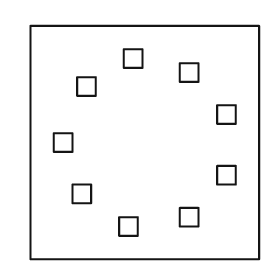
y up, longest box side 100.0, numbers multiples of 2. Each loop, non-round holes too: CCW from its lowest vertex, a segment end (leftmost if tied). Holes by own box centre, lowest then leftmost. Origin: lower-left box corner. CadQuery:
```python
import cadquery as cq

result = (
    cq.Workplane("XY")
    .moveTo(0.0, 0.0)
    .lineTo(98.0, 0.0)
    .lineTo(98.0, 100.0)
    .lineTo(0.0, 100.0)
    .close()
    .moveTo(38.0, 10.0)
    .lineTo(46.0, 10.0)
    .lineTo(46.0, 18.0)
    .lineTo(38.0, 18.0)
    .close()
    .moveTo(64.0, 14.0)
    .lineTo(72.0, 14.0)
    .lineTo(72.0, 22.0)
    .lineTo(64.0, 22.0)
    .close()
    .moveTo(18.0, 24.0)
    .lineTo(26.0, 24.0)
    .lineTo(26.0, 32.0)
    .lineTo(18.0, 32.0)
    .close()
    .moveTo(80.0, 32.0)
    .lineTo(88.0, 32.0)
    .lineTo(88.0, 40.0)
    .lineTo(80.0, 40.0)
    .close()
    .moveTo(10.0, 46.0)
    .lineTo(18.0, 46.0)
    .lineTo(18.0, 54.0)
    .lineTo(10.0, 54.0)
    .close()
    .moveTo(80.0, 58.0)
    .lineTo(88.0, 58.0)
    .lineTo(88.0, 66.0)
    .lineTo(80.0, 66.0)
    .close()
    .moveTo(20.0, 70.0)
    .lineTo(28.0, 70.0)
    .lineTo(28.0, 78.0)
    .lineTo(20.0, 78.0)
    .close()
    .moveTo(64.0, 76.0)
    .lineTo(72.0, 76.0)
    .lineTo(72.0, 84.0)
    .lineTo(64.0, 84.0)
    .close()
    .moveTo(40.0, 82.0)
    .lineTo(48.0, 82.0)
    .lineTo(48.0, 90.0)
    .lineTo(40.0, 90.0)
    .close()
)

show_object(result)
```